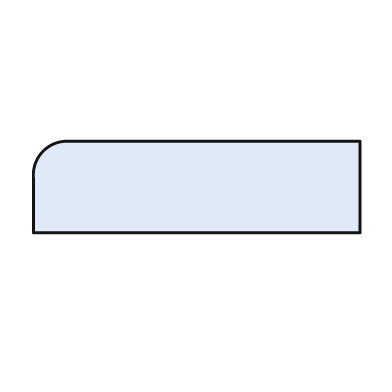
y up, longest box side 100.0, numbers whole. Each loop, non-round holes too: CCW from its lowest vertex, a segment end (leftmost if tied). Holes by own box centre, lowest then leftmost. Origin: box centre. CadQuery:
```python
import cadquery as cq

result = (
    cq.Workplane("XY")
    .moveTo(-50.0, -14.0)
    .lineTo(50.0, -14.0)
    .lineTo(50.0, 14.0)
    .lineTo(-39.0, 14.0)
    .threePointArc((-47.0, 11.0), (-50.0, 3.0))
    .close()
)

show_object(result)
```